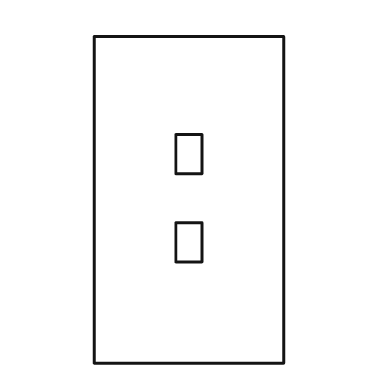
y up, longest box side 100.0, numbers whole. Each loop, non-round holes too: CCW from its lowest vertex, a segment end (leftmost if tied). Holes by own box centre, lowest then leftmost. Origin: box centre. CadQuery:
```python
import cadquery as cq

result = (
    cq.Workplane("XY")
    .moveTo(-29.0, -50.0)
    .lineTo(29.0, -50.0)
    .lineTo(29.0, 50.0)
    .lineTo(-29.0, 50.0)
    .close()
    .moveTo(-4.0, -19.0)
    .lineTo(4.0, -19.0)
    .lineTo(4.0, -7.0)
    .lineTo(-4.0, -7.0)
    .close()
    .moveTo(-4.0, 8.0)
    .lineTo(4.0, 8.0)
    .lineTo(4.0, 20.0)
    .lineTo(-4.0, 20.0)
    .close()
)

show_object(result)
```